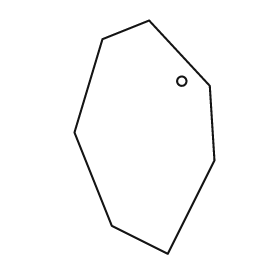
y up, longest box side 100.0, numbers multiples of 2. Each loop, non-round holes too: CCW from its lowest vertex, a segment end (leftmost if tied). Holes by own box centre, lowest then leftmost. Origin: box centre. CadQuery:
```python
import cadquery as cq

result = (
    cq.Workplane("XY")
    .moveTo(10.0, -50.0)
    .lineTo(30.0, -10.0)
    .lineTo(28.0, 22.0)
    .lineTo(2.0, 50.0)
    .lineTo(-18.0, 42.0)
    .lineTo(-30.0, 2.0)
    .lineTo(-14.0, -38.0)
    .close()
    .moveTo(16.0, 24.0)
    .circle(2.0)
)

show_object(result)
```